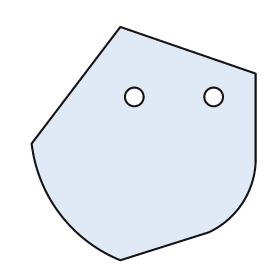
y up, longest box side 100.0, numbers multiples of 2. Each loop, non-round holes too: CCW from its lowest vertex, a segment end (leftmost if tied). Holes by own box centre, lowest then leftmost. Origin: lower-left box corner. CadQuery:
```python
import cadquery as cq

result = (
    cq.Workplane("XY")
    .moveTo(38.0, 0.0)
    .lineTo(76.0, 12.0)
    .threePointArc((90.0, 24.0), (96.0, 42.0))
    .lineTo(96.0, 80.0)
    .lineTo(38.0, 100.0)
    .lineTo(0.0, 50.0)
    .threePointArc((12.0, 20.0), (38.0, 0.0))
    .close()
    .moveTo(44.0, 70.0)
    .circle(4.0)
    .moveTo(78.0, 70.0)
    .circle(4.0)
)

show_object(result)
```